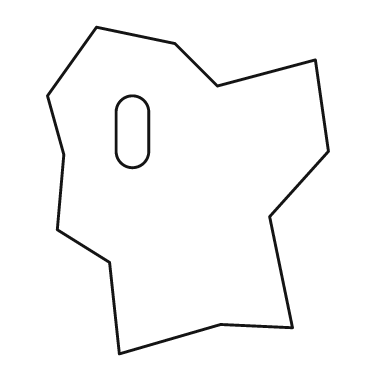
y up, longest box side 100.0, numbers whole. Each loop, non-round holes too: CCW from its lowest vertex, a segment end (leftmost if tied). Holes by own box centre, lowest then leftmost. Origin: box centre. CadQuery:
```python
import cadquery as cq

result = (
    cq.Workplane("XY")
    .moveTo(-21.0, -50.0)
    .lineTo(10.0, -41.0)
    .lineTo(32.0, -42.0)
    .lineTo(25.0, -8.0)
    .lineTo(43.0, 12.0)
    .lineTo(39.0, 40.0)
    .lineTo(9.0, 32.0)
    .lineTo(-4.0, 45.0)
    .lineTo(-28.0, 50.0)
    .lineTo(-43.0, 29.0)
    .lineTo(-38.0, 11.0)
    .lineTo(-40.0, -12.0)
    .lineTo(-24.0, -22.0)
    .close()
    .moveTo(-22.0, 12.0)
    .threePointArc((-17.0, 7.0), (-12.0, 12.0))
    .lineTo(-12.0, 24.0)
    .threePointArc((-17.0, 29.0), (-22.0, 24.0))
    .close()
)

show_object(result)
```